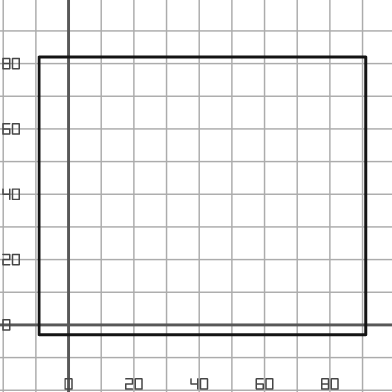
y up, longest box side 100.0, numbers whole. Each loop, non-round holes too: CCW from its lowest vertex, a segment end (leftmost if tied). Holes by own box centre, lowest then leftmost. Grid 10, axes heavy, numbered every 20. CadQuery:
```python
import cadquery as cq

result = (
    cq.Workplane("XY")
    .moveTo(-9.0, -3.0)
    .lineTo(91.0, -3.0)
    .lineTo(91.0, 82.0)
    .lineTo(-9.0, 82.0)
    .close()
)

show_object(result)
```